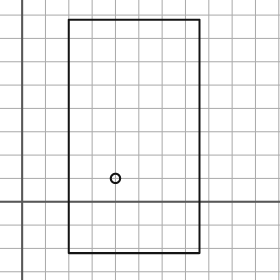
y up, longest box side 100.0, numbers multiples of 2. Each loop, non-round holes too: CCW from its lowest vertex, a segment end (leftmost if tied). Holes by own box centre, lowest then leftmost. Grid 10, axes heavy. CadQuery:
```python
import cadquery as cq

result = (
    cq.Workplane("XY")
    .moveTo(20.0, -22.0)
    .lineTo(76.0, -22.0)
    .lineTo(76.0, 78.0)
    .lineTo(20.0, 78.0)
    .close()
    .moveTo(40.0, 10.0)
    .circle(2.0)
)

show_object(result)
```